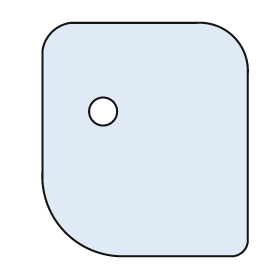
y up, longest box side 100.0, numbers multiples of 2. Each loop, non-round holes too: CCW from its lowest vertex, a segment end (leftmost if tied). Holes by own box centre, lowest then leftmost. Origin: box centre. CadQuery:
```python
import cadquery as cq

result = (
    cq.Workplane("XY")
    .moveTo(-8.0, -50.0)
    .lineTo(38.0, -50.0)
    .threePointArc((42.0, -48.0), (44.0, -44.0))
    .lineTo(44.0, 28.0)
    .threePointArc((38.0, 44.0), (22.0, 50.0))
    .lineTo(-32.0, 50.0)
    .threePointArc((-40.0, 46.0), (-44.0, 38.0))
    .lineTo(-44.0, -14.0)
    .threePointArc((-34.0, -40.0), (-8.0, -50.0))
    .close()
    .moveTo(-18.0, 12.0)
    .circle(6.0)
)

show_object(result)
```